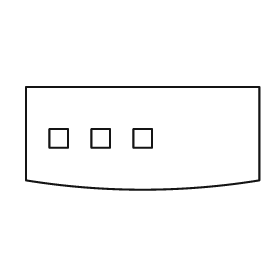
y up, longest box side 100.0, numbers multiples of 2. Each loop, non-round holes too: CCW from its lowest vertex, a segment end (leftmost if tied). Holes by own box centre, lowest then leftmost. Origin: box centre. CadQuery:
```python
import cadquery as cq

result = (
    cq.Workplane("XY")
    .moveTo(-50.0, -18.0)
    .threePointArc((0.0, -22.0), (50.0, -18.0))
    .lineTo(50.0, 22.0)
    .lineTo(-50.0, 22.0)
    .close()
    .moveTo(-40.0, -4.0)
    .lineTo(-32.0, -4.0)
    .lineTo(-32.0, 4.0)
    .lineTo(-40.0, 4.0)
    .close()
    .moveTo(-22.0, -4.0)
    .lineTo(-14.0, -4.0)
    .lineTo(-14.0, 4.0)
    .lineTo(-22.0, 4.0)
    .close()
    .moveTo(-4.0, -4.0)
    .lineTo(4.0, -4.0)
    .lineTo(4.0, 4.0)
    .lineTo(-4.0, 4.0)
    .close()
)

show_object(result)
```